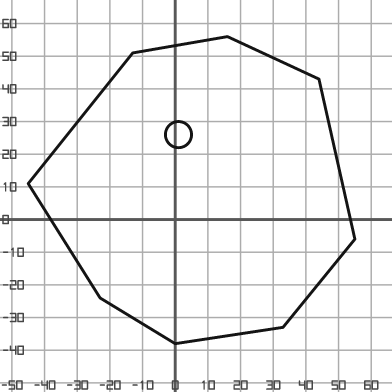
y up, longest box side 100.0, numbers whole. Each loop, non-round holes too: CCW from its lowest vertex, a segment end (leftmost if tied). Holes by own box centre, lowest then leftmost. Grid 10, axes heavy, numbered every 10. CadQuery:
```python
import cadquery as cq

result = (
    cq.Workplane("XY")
    .moveTo(0.0, -38.0)
    .lineTo(33.0, -33.0)
    .lineTo(55.0, -6.0)
    .lineTo(44.0, 43.0)
    .lineTo(16.0, 56.0)
    .lineTo(-13.0, 51.0)
    .lineTo(-45.0, 11.0)
    .lineTo(-23.0, -24.0)
    .close()
    .moveTo(1.0, 26.0)
    .circle(4.0)
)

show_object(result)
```